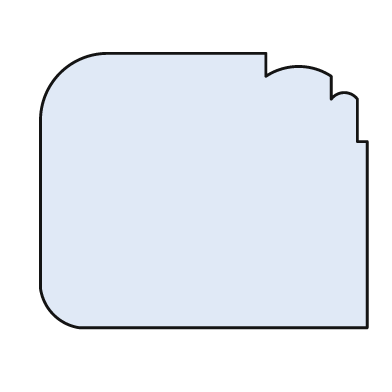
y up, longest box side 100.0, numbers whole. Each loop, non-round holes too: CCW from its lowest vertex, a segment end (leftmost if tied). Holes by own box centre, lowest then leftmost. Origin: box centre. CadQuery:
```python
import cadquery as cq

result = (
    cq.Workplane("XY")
    .moveTo(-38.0, -42.0)
    .lineTo(50.0, -42.0)
    .lineTo(50.0, 15.0)
    .lineTo(47.0, 15.0)
    .lineTo(47.0, 28.0)
    .threePointArc((43.0, 30.0), (39.0, 28.0))
    .lineTo(39.0, 35.0)
    .threePointArc((29.0, 38.0), (19.0, 35.0))
    .lineTo(19.0, 42.0)
    .lineTo(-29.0, 42.0)
    .threePointArc((-44.0, 36.0), (-50.0, 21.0))
    .lineTo(-50.0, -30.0)
    .threePointArc((-46.0, -38.0), (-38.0, -42.0))
    .close()
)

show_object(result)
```